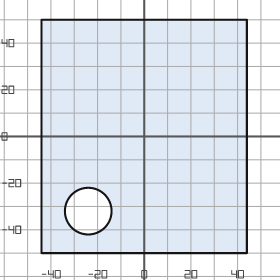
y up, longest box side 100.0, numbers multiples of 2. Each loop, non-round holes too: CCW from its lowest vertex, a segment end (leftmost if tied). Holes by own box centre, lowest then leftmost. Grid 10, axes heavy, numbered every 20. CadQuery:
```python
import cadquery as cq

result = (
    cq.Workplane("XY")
    .moveTo(-44.0, -50.0)
    .lineTo(44.0, -50.0)
    .lineTo(44.0, 50.0)
    .lineTo(-44.0, 50.0)
    .close()
    .moveTo(-24.0, -32.0)
    .circle(10.0)
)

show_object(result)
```